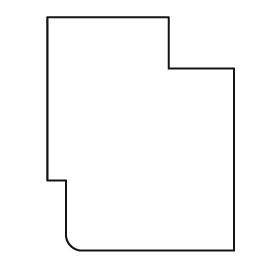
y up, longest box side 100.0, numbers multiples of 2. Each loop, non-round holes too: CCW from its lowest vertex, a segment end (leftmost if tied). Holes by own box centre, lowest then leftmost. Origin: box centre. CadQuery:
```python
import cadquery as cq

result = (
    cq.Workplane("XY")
    .moveTo(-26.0, -50.0)
    .lineTo(40.0, -50.0)
    .lineTo(40.0, 28.0)
    .lineTo(12.0, 28.0)
    .lineTo(12.0, 50.0)
    .lineTo(-40.0, 50.0)
    .lineTo(-40.0, -20.0)
    .lineTo(-32.0, -20.0)
    .lineTo(-32.0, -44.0)
    .threePointArc((-30.0, -48.0), (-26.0, -50.0))
    .close()
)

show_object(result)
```